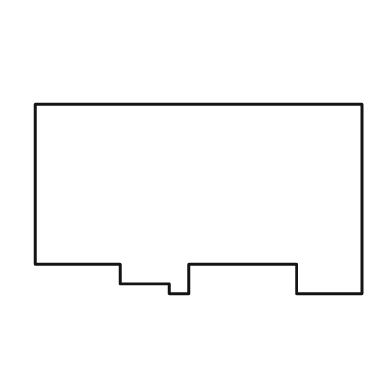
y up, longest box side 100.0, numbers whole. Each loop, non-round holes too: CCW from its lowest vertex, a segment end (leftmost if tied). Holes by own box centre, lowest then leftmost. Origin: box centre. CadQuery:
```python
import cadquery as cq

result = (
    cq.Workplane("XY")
    .moveTo(-9.0, -29.0)
    .lineTo(-3.0, -29.0)
    .lineTo(-3.0, -20.0)
    .lineTo(30.0, -20.0)
    .lineTo(30.0, -29.0)
    .lineTo(50.0, -29.0)
    .lineTo(50.0, 29.0)
    .lineTo(-50.0, 29.0)
    .lineTo(-50.0, -20.0)
    .lineTo(-24.0, -20.0)
    .lineTo(-24.0, -26.0)
    .lineTo(-9.0, -26.0)
    .close()
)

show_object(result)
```